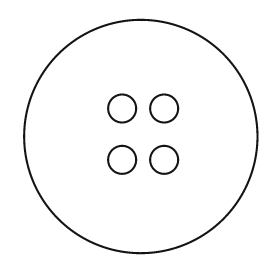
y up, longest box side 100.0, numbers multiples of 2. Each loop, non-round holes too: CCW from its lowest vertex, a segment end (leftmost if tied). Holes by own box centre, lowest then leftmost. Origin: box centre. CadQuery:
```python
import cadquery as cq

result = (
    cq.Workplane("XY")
    .moveTo(0.0, 0.0)
    .circle(50.0)
    .moveTo(-8.0, -10.0)
    .circle(6.0)
    .moveTo(10.0, -10.0)
    .circle(6.0)
    .moveTo(-8.0, 12.0)
    .circle(6.0)
    .moveTo(10.0, 12.0)
    .circle(6.0)
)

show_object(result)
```